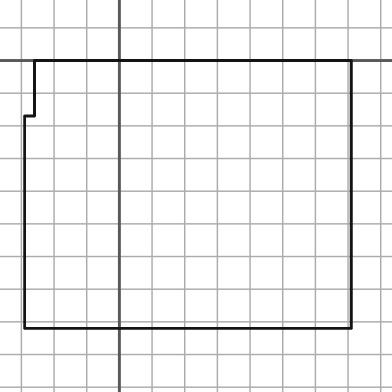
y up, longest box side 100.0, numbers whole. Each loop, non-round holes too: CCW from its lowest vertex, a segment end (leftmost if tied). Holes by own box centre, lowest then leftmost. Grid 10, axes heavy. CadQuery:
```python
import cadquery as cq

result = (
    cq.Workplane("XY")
    .moveTo(-29.0, -82.0)
    .lineTo(71.0, -82.0)
    .lineTo(71.0, 0.0)
    .lineTo(-26.0, 0.0)
    .lineTo(-26.0, -17.0)
    .lineTo(-29.0, -17.0)
    .close()
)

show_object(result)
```